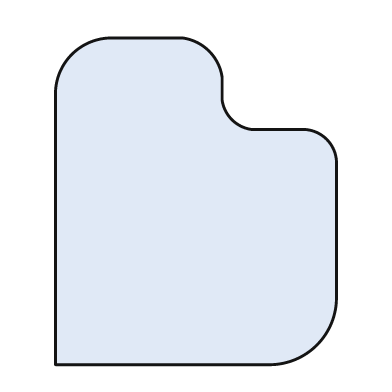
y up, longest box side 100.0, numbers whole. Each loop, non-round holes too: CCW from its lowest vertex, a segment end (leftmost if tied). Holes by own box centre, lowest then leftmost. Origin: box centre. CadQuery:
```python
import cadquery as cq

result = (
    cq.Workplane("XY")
    .moveTo(-43.0, -50.0)
    .lineTo(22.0, -50.0)
    .threePointArc((37.0, -44.0), (43.0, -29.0))
    .lineTo(43.0, 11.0)
    .threePointArc((40.0, 19.0), (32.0, 22.0))
    .lineTo(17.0, 22.0)
    .threePointArc((11.0, 25.0), (8.0, 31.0))
    .lineTo(8.0, 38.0)
    .threePointArc((4.0, 46.0), (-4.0, 50.0))
    .lineTo(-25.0, 50.0)
    .threePointArc((-38.0, 45.0), (-43.0, 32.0))
    .close()
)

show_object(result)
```